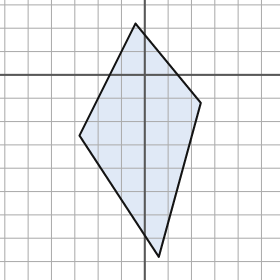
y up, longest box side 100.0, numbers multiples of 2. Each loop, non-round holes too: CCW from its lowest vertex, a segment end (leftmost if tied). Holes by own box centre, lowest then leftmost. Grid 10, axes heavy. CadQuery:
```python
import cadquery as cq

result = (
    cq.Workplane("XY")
    .moveTo(6.0, -78.0)
    .lineTo(24.0, -12.0)
    .lineTo(-4.0, 22.0)
    .lineTo(-28.0, -26.0)
    .close()
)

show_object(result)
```